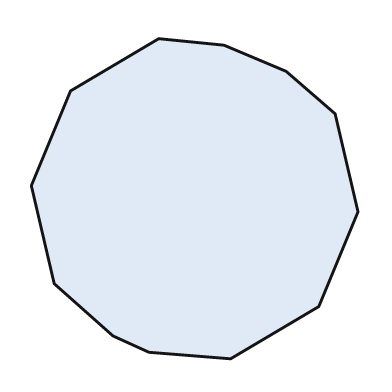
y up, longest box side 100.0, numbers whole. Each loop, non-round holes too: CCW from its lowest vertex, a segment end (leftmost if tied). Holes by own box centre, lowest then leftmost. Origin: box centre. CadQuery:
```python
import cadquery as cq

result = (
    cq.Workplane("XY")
    .moveTo(11.0, -49.0)
    .lineTo(38.0, -33.0)
    .lineTo(50.0, -4.0)
    .lineTo(43.0, 26.0)
    .lineTo(28.0, 39.0)
    .lineTo(9.0, 47.0)
    .lineTo(-11.0, 49.0)
    .lineTo(-38.0, 33.0)
    .lineTo(-50.0, 4.0)
    .lineTo(-43.0, -26.0)
    .lineTo(-25.0, -42.0)
    .lineTo(-14.0, -47.0)
    .close()
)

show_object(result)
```